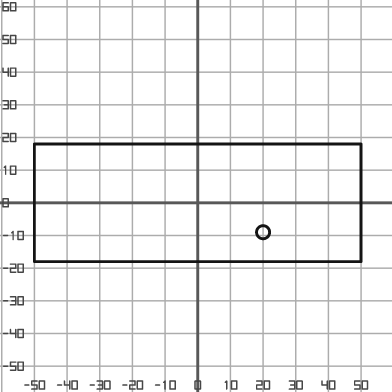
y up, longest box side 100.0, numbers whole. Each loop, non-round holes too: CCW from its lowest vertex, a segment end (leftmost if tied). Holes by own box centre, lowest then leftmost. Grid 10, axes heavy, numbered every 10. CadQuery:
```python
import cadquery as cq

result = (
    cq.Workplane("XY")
    .moveTo(-50.0, -18.0)
    .lineTo(50.0, -18.0)
    .lineTo(50.0, 18.0)
    .lineTo(-50.0, 18.0)
    .close()
    .moveTo(20.0, -9.0)
    .circle(2.0)
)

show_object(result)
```